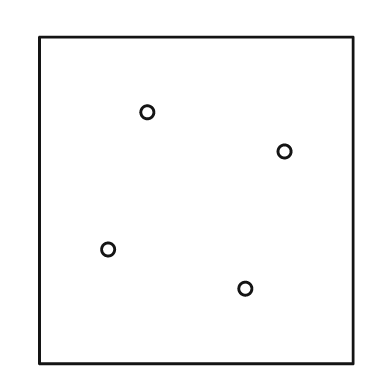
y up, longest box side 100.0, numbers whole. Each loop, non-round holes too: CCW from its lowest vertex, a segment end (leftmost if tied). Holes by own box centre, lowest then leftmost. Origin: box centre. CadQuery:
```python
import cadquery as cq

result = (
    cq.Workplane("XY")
    .moveTo(-48.0, -50.0)
    .lineTo(48.0, -50.0)
    .lineTo(48.0, 50.0)
    .lineTo(-48.0, 50.0)
    .close()
    .moveTo(15.0, -27.0)
    .circle(2.0)
    .moveTo(-27.0, -15.0)
    .circle(2.0)
    .moveTo(27.0, 15.0)
    .circle(2.0)
    .moveTo(-15.0, 27.0)
    .circle(2.0)
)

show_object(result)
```